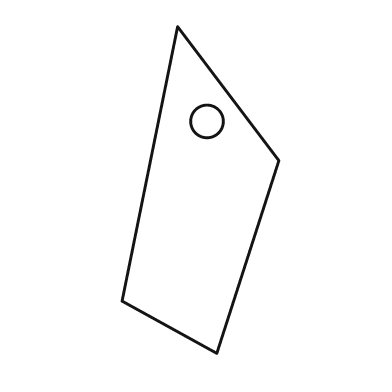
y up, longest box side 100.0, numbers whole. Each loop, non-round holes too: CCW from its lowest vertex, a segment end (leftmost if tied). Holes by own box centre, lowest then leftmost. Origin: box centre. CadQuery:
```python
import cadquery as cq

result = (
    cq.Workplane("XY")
    .moveTo(5.0, -50.0)
    .lineTo(24.0, 9.0)
    .lineTo(-7.0, 50.0)
    .lineTo(-24.0, -34.0)
    .close()
    .moveTo(2.0, 21.0)
    .circle(5.0)
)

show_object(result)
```